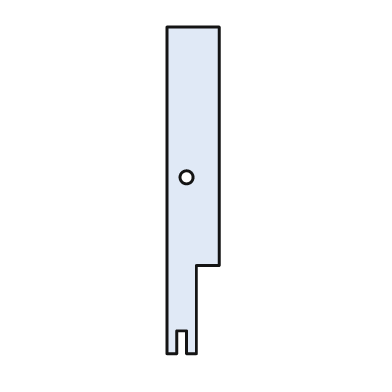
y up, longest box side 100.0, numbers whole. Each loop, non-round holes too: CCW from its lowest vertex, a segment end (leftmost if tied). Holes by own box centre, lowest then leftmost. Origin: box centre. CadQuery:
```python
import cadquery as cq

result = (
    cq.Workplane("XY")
    .moveTo(-8.0, -50.0)
    .lineTo(-5.0, -50.0)
    .lineTo(-5.0, -43.0)
    .lineTo(-2.0, -43.0)
    .lineTo(-2.0, -50.0)
    .lineTo(1.0, -50.0)
    .lineTo(1.0, -23.0)
    .lineTo(8.0, -23.0)
    .lineTo(8.0, 50.0)
    .lineTo(-8.0, 50.0)
    .close()
    .moveTo(-2.0, 4.0)
    .circle(2.0)
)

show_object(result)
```